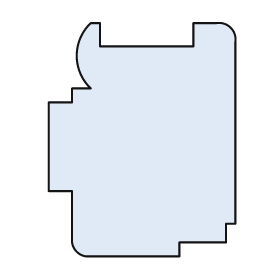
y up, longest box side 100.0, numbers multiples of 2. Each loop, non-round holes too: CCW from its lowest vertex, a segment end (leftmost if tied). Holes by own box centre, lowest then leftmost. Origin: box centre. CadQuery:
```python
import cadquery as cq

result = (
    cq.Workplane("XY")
    .moveTo(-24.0, -50.0)
    .lineTo(16.0, -50.0)
    .lineTo(16.0, -44.0)
    .lineTo(36.0, -44.0)
    .lineTo(36.0, -36.0)
    .lineTo(40.0, -36.0)
    .lineTo(40.0, 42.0)
    .threePointArc((38.0, 48.0), (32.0, 50.0))
    .lineTo(22.0, 50.0)
    .lineTo(22.0, 40.0)
    .lineTo(-18.0, 40.0)
    .lineTo(-18.0, 50.0)
    .lineTo(-22.0, 50.0)
    .threePointArc((-28.0, 36.0), (-22.0, 22.0))
    .lineTo(-30.0, 22.0)
    .lineTo(-30.0, 16.0)
    .lineTo(-40.0, 16.0)
    .lineTo(-40.0, -22.0)
    .lineTo(-30.0, -22.0)
    .lineTo(-30.0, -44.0)
    .threePointArc((-28.0, -48.0), (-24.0, -50.0))
    .close()
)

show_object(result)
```